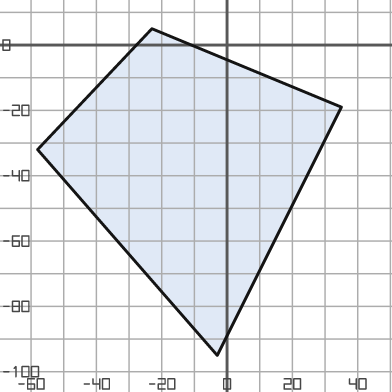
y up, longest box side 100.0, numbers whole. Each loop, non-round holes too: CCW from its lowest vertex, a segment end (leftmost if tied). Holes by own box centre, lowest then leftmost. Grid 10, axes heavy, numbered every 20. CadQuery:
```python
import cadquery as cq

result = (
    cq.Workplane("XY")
    .moveTo(-3.0, -95.0)
    .lineTo(35.0, -19.0)
    .lineTo(-23.0, 5.0)
    .lineTo(-58.0, -32.0)
    .close()
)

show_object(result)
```